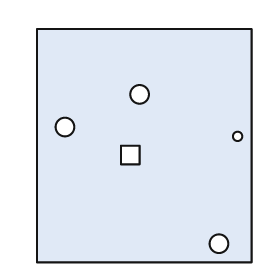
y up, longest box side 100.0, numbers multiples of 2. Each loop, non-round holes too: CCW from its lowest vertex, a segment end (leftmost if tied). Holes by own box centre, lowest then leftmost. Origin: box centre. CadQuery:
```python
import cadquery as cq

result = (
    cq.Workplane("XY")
    .moveTo(-46.0, -50.0)
    .lineTo(46.0, -50.0)
    .lineTo(46.0, 50.0)
    .lineTo(-46.0, 50.0)
    .close()
    .moveTo(32.0, -42.0)
    .circle(4.0)
    .moveTo(-10.0, -8.0)
    .lineTo(-2.0, -8.0)
    .lineTo(-2.0, 0.0)
    .lineTo(-10.0, 0.0)
    .close()
    .moveTo(40.0, 4.0)
    .circle(2.0)
    .moveTo(-34.0, 8.0)
    .circle(4.0)
    .moveTo(-2.0, 22.0)
    .circle(4.0)
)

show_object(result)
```